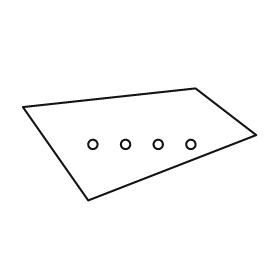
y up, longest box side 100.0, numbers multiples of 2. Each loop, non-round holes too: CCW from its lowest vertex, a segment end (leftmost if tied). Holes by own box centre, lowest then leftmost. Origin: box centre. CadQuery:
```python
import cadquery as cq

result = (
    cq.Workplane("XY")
    .moveTo(-22.0, -24.0)
    .lineTo(50.0, 4.0)
    .lineTo(24.0, 24.0)
    .lineTo(-50.0, 16.0)
    .close()
    .moveTo(-20.0, 0.0)
    .circle(2.0)
    .moveTo(-6.0, 0.0)
    .circle(2.0)
    .moveTo(8.0, 0.0)
    .circle(2.0)
    .moveTo(22.0, 0.0)
    .circle(2.0)
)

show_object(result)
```